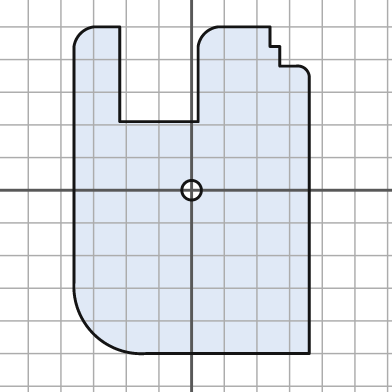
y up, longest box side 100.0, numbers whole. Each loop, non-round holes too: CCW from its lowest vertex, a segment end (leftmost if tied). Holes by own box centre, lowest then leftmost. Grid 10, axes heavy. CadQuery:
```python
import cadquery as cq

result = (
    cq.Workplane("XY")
    .moveTo(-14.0, -50.0)
    .lineTo(36.0, -50.0)
    .lineTo(36.0, 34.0)
    .threePointArc((35.0, 37.0), (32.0, 38.0))
    .lineTo(27.0, 38.0)
    .lineTo(27.0, 44.0)
    .lineTo(24.0, 44.0)
    .lineTo(24.0, 50.0)
    .lineTo(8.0, 50.0)
    .threePointArc((4.0, 48.0), (2.0, 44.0))
    .lineTo(2.0, 21.0)
    .lineTo(-22.0, 21.0)
    .lineTo(-22.0, 50.0)
    .lineTo(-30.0, 50.0)
    .threePointArc((-34.0, 48.0), (-36.0, 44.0))
    .lineTo(-36.0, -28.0)
    .threePointArc((-30.0, -44.0), (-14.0, -50.0))
    .close()
    .moveTo(0.0, 0.0)
    .circle(3.0)
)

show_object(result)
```